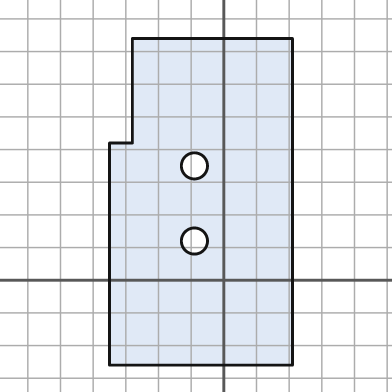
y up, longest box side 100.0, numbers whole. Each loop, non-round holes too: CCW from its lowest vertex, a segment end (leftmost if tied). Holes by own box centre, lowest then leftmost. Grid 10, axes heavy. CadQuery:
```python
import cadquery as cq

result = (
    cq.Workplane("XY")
    .moveTo(-35.0, -26.0)
    .lineTo(21.0, -26.0)
    .lineTo(21.0, 74.0)
    .lineTo(-28.0, 74.0)
    .lineTo(-28.0, 42.0)
    .lineTo(-35.0, 42.0)
    .close()
    .moveTo(-9.0, 12.0)
    .circle(4.0)
    .moveTo(-9.0, 35.0)
    .circle(4.0)
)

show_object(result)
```